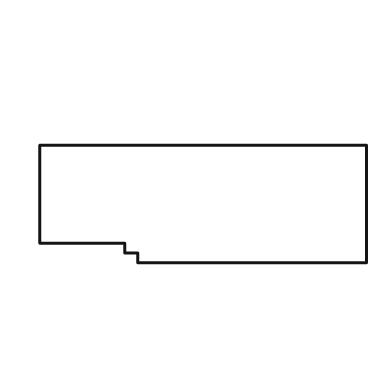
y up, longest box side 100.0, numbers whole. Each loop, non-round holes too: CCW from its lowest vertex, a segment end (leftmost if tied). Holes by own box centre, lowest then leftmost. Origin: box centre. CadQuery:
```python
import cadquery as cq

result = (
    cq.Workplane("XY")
    .moveTo(-20.0, -18.0)
    .lineTo(50.0, -18.0)
    .lineTo(50.0, 18.0)
    .lineTo(-50.0, 18.0)
    .lineTo(-50.0, -12.0)
    .lineTo(-24.0, -12.0)
    .lineTo(-24.0, -15.0)
    .lineTo(-20.0, -15.0)
    .close()
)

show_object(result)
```